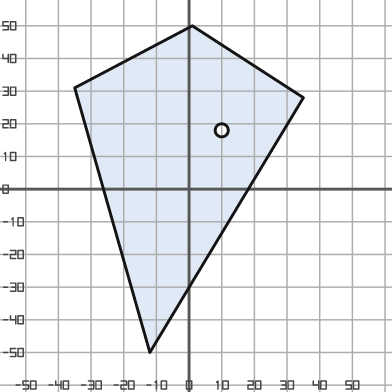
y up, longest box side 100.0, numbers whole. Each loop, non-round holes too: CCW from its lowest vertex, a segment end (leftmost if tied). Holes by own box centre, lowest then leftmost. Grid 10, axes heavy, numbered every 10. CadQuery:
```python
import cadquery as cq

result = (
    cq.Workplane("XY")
    .moveTo(-12.0, -50.0)
    .lineTo(35.0, 28.0)
    .lineTo(1.0, 50.0)
    .lineTo(-35.0, 31.0)
    .close()
    .moveTo(10.0, 18.0)
    .circle(2.0)
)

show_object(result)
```